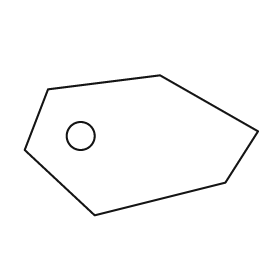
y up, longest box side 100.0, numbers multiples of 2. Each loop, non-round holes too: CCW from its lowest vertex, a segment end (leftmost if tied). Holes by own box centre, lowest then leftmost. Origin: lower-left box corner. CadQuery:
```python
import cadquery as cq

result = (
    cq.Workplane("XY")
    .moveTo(30.0, 0.0)
    .lineTo(86.0, 14.0)
    .lineTo(100.0, 36.0)
    .lineTo(58.0, 60.0)
    .lineTo(10.0, 54.0)
    .lineTo(0.0, 28.0)
    .close()
    .moveTo(24.0, 34.0)
    .circle(6.0)
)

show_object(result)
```